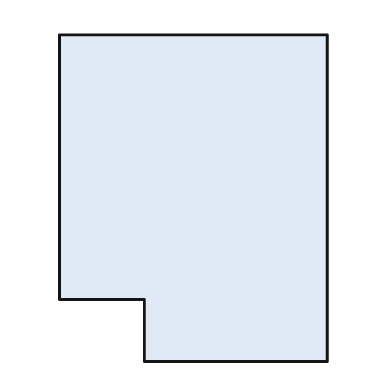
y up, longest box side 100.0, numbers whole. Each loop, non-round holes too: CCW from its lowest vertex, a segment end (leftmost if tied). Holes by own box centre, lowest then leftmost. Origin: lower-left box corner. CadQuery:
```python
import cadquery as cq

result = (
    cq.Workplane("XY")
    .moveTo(26.0, 0.0)
    .lineTo(82.0, 0.0)
    .lineTo(82.0, 100.0)
    .lineTo(0.0, 100.0)
    .lineTo(0.0, 19.0)
    .lineTo(26.0, 19.0)
    .close()
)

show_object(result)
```